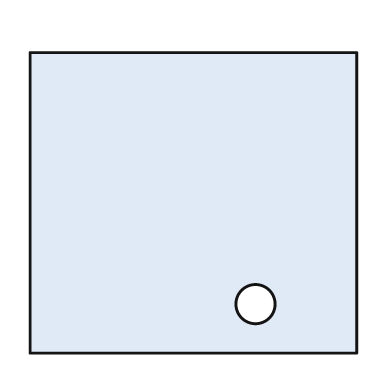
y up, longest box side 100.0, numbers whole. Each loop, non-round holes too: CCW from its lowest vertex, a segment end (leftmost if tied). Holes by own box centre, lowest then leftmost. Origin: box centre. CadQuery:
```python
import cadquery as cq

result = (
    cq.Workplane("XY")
    .moveTo(-50.0, -46.0)
    .lineTo(50.0, -46.0)
    .lineTo(50.0, 46.0)
    .lineTo(-50.0, 46.0)
    .close()
    .moveTo(19.0, -31.0)
    .circle(6.0)
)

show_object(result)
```